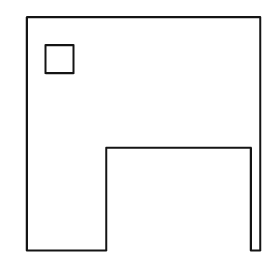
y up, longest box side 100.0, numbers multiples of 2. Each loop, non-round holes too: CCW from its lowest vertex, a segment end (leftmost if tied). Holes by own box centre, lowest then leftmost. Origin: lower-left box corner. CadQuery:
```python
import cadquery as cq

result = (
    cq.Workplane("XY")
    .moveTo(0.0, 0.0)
    .lineTo(34.0, 0.0)
    .lineTo(34.0, 44.0)
    .lineTo(96.0, 44.0)
    .lineTo(96.0, 0.0)
    .lineTo(100.0, 0.0)
    .lineTo(100.0, 100.0)
    .lineTo(0.0, 100.0)
    .close()
    .moveTo(8.0, 76.0)
    .lineTo(20.0, 76.0)
    .lineTo(20.0, 88.0)
    .lineTo(8.0, 88.0)
    .close()
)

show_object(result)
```